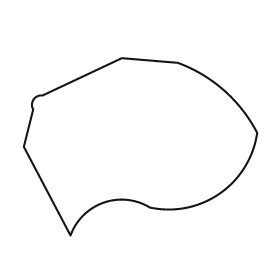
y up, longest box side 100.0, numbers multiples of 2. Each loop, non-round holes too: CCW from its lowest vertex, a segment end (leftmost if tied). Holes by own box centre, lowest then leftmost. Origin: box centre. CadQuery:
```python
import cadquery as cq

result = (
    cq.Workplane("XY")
    .moveTo(-30.0, -38.0)
    .threePointArc((-16.0, -24.0), (4.0, -26.0))
    .threePointArc((34.0, -20.0), (50.0, 6.0))
    .threePointArc((36.0, 24.0), (16.0, 36.0))
    .lineTo(-8.0, 38.0)
    .lineTo(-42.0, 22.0)
    .threePointArc((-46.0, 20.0), (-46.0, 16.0))
    .lineTo(-50.0, 0.0)
    .close()
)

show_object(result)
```